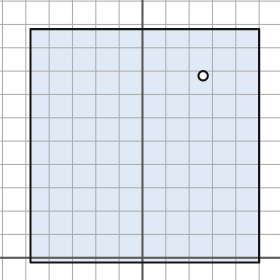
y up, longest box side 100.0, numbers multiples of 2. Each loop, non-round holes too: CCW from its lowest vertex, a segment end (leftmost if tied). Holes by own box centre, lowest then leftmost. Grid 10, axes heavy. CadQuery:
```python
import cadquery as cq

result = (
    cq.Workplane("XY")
    .moveTo(-48.0, -2.0)
    .lineTo(50.0, -2.0)
    .lineTo(50.0, 98.0)
    .lineTo(-48.0, 98.0)
    .close()
    .moveTo(26.0, 78.0)
    .circle(2.0)
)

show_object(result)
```